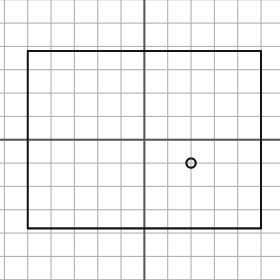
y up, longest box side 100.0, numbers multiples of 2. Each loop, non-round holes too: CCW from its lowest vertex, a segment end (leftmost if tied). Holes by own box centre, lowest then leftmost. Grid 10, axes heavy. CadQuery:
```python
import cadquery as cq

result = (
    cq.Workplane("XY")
    .moveTo(-50.0, -38.0)
    .lineTo(50.0, -38.0)
    .lineTo(50.0, 38.0)
    .lineTo(-50.0, 38.0)
    .close()
    .moveTo(20.0, -10.0)
    .circle(2.0)
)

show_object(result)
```